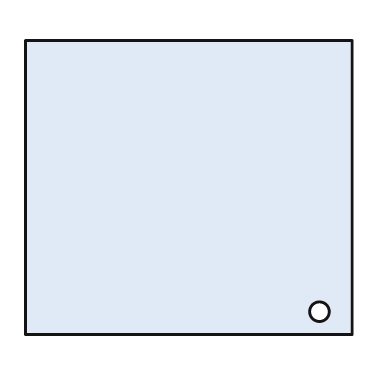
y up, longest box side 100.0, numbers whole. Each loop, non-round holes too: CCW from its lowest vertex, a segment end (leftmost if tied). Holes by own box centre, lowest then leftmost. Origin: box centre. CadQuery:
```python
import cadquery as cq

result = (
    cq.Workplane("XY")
    .moveTo(-50.0, -45.0)
    .lineTo(50.0, -45.0)
    .lineTo(50.0, 45.0)
    .lineTo(-50.0, 45.0)
    .close()
    .moveTo(40.0, -38.0)
    .circle(3.0)
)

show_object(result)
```